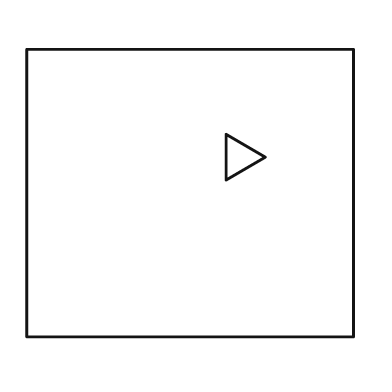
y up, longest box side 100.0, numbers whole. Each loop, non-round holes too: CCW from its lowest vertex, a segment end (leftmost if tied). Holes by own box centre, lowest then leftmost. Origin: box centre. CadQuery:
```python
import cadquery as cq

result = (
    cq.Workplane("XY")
    .moveTo(-50.0, -44.0)
    .lineTo(50.0, -44.0)
    .lineTo(50.0, 44.0)
    .lineTo(-50.0, 44.0)
    .close()
    .moveTo(11.0, 4.0)
    .lineTo(23.0, 11.0)
    .lineTo(11.0, 18.0)
    .close()
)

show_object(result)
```